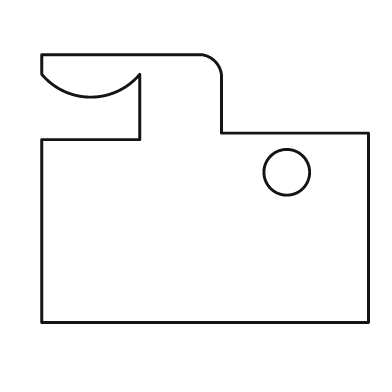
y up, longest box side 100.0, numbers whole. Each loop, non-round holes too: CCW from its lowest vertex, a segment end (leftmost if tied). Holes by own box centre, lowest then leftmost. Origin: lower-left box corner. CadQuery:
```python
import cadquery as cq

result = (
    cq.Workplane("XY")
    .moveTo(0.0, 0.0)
    .lineTo(100.0, 0.0)
    .lineTo(100.0, 58.0)
    .lineTo(55.0, 58.0)
    .lineTo(55.0, 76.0)
    .threePointArc((53.0, 80.0), (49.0, 82.0))
    .lineTo(0.0, 82.0)
    .lineTo(0.0, 76.0)
    .threePointArc((15.0, 69.0), (30.0, 76.0))
    .lineTo(30.0, 56.0)
    .lineTo(0.0, 56.0)
    .close()
    .moveTo(75.0, 46.0)
    .circle(7.0)
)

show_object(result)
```